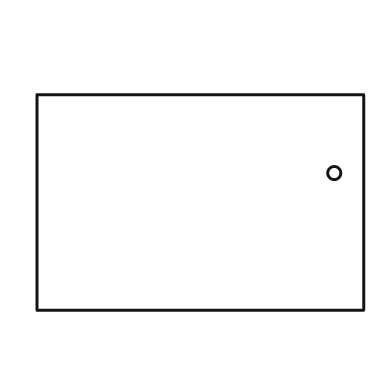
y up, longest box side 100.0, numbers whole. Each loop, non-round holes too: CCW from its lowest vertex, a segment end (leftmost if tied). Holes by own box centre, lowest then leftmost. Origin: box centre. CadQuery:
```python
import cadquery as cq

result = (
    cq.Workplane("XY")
    .moveTo(-50.0, -33.0)
    .lineTo(50.0, -33.0)
    .lineTo(50.0, 33.0)
    .lineTo(-50.0, 33.0)
    .close()
    .moveTo(41.0, 9.0)
    .circle(2.0)
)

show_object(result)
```